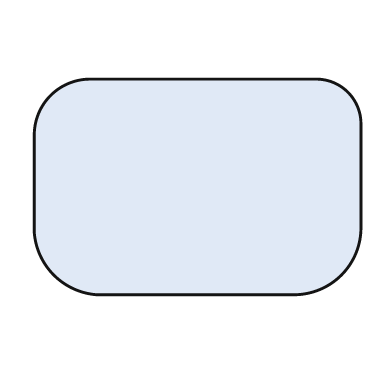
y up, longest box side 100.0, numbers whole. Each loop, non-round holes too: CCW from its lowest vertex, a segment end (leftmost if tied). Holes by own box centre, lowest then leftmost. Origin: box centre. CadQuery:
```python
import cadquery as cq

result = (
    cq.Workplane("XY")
    .moveTo(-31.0, -33.0)
    .lineTo(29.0, -33.0)
    .threePointArc((44.0, -27.0), (50.0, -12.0))
    .lineTo(50.0, 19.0)
    .threePointArc((46.0, 29.0), (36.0, 33.0))
    .lineTo(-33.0, 33.0)
    .threePointArc((-45.0, 28.0), (-50.0, 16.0))
    .lineTo(-50.0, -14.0)
    .threePointArc((-44.0, -27.0), (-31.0, -33.0))
    .close()
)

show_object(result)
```